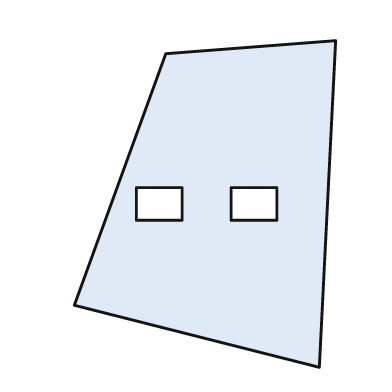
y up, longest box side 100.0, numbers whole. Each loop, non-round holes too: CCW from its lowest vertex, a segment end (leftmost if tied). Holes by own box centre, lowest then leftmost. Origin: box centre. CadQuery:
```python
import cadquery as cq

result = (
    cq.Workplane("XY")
    .moveTo(35.0, -50.0)
    .lineTo(40.0, 50.0)
    .lineTo(-12.0, 46.0)
    .lineTo(-40.0, -31.0)
    .close()
    .moveTo(-21.0, -5.0)
    .lineTo(-7.0, -5.0)
    .lineTo(-7.0, 5.0)
    .lineTo(-21.0, 5.0)
    .close()
    .moveTo(8.0, -5.0)
    .lineTo(22.0, -5.0)
    .lineTo(22.0, 5.0)
    .lineTo(8.0, 5.0)
    .close()
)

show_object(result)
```